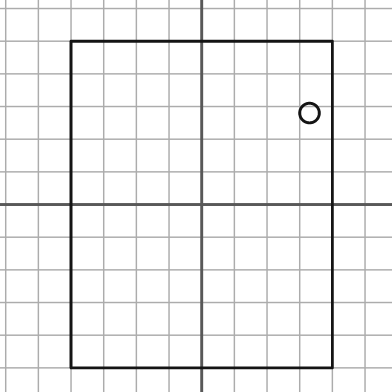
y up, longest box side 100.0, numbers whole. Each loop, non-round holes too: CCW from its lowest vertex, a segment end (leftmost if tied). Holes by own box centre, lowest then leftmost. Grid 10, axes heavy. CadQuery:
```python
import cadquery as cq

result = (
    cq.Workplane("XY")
    .moveTo(-40.0, -50.0)
    .lineTo(40.0, -50.0)
    .lineTo(40.0, 50.0)
    .lineTo(-40.0, 50.0)
    .close()
    .moveTo(33.0, 28.0)
    .circle(3.0)
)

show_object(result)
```